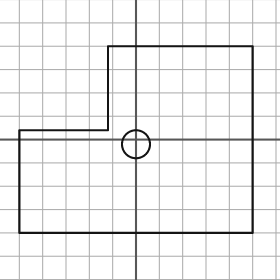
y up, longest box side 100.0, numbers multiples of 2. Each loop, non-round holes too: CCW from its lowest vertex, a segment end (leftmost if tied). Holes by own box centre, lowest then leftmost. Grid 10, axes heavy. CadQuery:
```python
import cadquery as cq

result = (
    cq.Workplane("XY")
    .moveTo(-50.0, -40.0)
    .lineTo(50.0, -40.0)
    .lineTo(50.0, 40.0)
    .lineTo(-12.0, 40.0)
    .lineTo(-12.0, 4.0)
    .lineTo(-50.0, 4.0)
    .close()
    .moveTo(0.0, -2.0)
    .circle(6.0)
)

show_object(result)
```